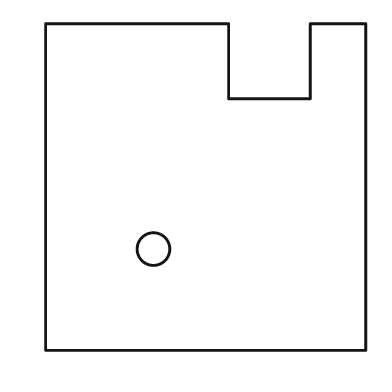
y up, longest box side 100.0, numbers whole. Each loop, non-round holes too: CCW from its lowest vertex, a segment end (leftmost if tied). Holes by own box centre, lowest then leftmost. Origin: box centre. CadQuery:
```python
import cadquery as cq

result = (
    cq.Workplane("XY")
    .moveTo(-49.0, -50.0)
    .lineTo(49.0, -50.0)
    .lineTo(49.0, 50.0)
    .lineTo(32.0, 50.0)
    .lineTo(32.0, 27.0)
    .lineTo(7.0, 27.0)
    .lineTo(7.0, 50.0)
    .lineTo(-49.0, 50.0)
    .close()
    .moveTo(-16.0, -19.0)
    .circle(5.0)
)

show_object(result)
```